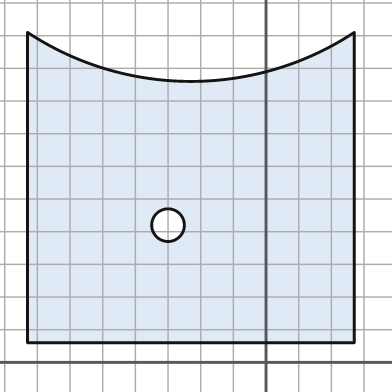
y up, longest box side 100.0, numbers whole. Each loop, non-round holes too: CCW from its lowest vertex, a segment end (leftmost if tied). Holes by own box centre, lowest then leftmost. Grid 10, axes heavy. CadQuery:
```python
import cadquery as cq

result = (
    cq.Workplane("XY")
    .moveTo(-73.0, 6.0)
    .lineTo(27.0, 6.0)
    .lineTo(27.0, 101.0)
    .threePointArc((-23.0, 86.0), (-73.0, 101.0))
    .close()
    .moveTo(-30.0, 42.0)
    .circle(5.0)
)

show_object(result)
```